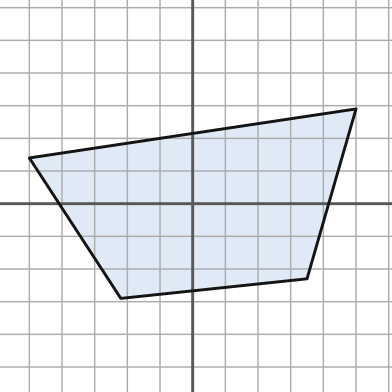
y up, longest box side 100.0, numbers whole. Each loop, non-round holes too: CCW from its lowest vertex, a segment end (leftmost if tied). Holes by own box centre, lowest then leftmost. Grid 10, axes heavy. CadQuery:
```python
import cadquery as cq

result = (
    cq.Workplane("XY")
    .moveTo(-22.0, -29.0)
    .lineTo(35.0, -23.0)
    .lineTo(50.0, 29.0)
    .lineTo(-50.0, 14.0)
    .close()
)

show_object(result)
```